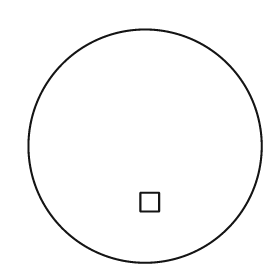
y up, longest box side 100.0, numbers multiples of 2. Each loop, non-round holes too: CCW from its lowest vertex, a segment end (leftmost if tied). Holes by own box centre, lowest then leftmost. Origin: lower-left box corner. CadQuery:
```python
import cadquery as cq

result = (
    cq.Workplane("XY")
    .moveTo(50.0, 50.0)
    .circle(50.0)
    .moveTo(48.0, 22.0)
    .lineTo(56.0, 22.0)
    .lineTo(56.0, 30.0)
    .lineTo(48.0, 30.0)
    .close()
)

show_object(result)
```